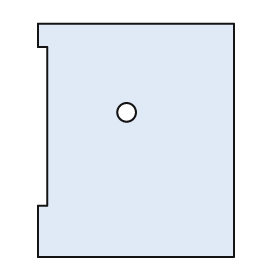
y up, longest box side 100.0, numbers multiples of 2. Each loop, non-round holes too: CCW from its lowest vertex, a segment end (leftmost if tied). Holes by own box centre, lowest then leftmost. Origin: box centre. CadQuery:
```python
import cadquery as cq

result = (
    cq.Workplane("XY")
    .moveTo(-42.0, -50.0)
    .lineTo(42.0, -50.0)
    .lineTo(42.0, 50.0)
    .lineTo(-42.0, 50.0)
    .lineTo(-42.0, 40.0)
    .lineTo(-38.0, 40.0)
    .lineTo(-38.0, -28.0)
    .lineTo(-42.0, -28.0)
    .close()
    .moveTo(-4.0, 12.0)
    .circle(4.0)
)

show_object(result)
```